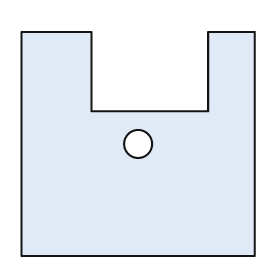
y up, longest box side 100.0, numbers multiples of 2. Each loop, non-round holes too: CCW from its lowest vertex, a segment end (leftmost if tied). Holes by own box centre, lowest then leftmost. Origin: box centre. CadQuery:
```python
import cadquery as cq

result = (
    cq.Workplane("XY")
    .moveTo(-50.0, -48.0)
    .lineTo(50.0, -48.0)
    .lineTo(50.0, 48.0)
    .lineTo(30.0, 48.0)
    .lineTo(30.0, 14.0)
    .lineTo(-20.0, 14.0)
    .lineTo(-20.0, 48.0)
    .lineTo(-50.0, 48.0)
    .close()
    .moveTo(0.0, 0.0)
    .circle(6.0)
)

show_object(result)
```